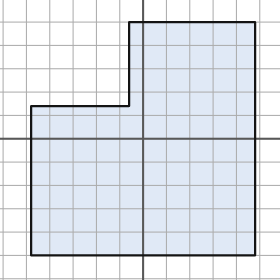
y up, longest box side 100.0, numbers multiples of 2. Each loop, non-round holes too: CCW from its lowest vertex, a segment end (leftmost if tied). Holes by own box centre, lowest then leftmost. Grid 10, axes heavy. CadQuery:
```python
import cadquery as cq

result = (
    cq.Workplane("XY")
    .moveTo(-48.0, -50.0)
    .lineTo(48.0, -50.0)
    .lineTo(48.0, 50.0)
    .lineTo(-6.0, 50.0)
    .lineTo(-6.0, 14.0)
    .lineTo(-48.0, 14.0)
    .close()
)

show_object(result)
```